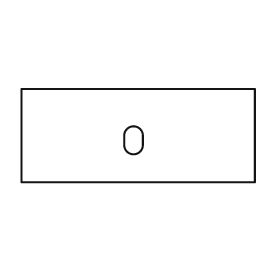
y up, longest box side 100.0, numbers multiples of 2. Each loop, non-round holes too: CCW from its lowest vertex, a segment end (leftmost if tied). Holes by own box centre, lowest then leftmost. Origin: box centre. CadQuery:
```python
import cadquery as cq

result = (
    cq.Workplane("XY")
    .moveTo(-50.0, -20.0)
    .lineTo(50.0, -20.0)
    .lineTo(50.0, 20.0)
    .lineTo(-50.0, 20.0)
    .close()
    .moveTo(-6.0, -4.0)
    .threePointArc((-2.0, -8.0), (2.0, -4.0))
    .lineTo(2.0, 0.0)
    .threePointArc((-2.0, 4.0), (-6.0, 0.0))
    .close()
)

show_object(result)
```